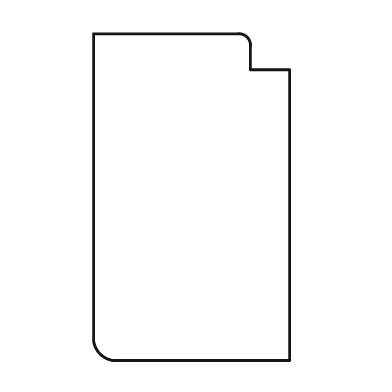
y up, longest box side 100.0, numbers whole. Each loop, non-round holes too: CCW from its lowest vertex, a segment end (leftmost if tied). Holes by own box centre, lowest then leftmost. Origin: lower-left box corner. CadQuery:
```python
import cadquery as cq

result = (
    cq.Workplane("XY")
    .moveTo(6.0, 0.0)
    .lineTo(60.0, 0.0)
    .lineTo(60.0, 89.0)
    .lineTo(48.0, 89.0)
    .lineTo(48.0, 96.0)
    .threePointArc((47.0, 99.0), (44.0, 100.0))
    .lineTo(0.0, 100.0)
    .lineTo(0.0, 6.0)
    .threePointArc((2.0, 2.0), (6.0, 0.0))
    .close()
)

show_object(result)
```